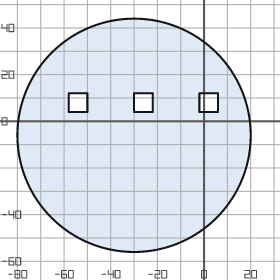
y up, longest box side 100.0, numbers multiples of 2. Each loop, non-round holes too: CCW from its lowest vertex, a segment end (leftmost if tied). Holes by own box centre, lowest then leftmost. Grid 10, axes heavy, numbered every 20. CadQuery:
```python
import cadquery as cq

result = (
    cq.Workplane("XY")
    .moveTo(-30.0, -6.0)
    .circle(50.0)
    .moveTo(-58.0, 4.0)
    .lineTo(-50.0, 4.0)
    .lineTo(-50.0, 12.0)
    .lineTo(-58.0, 12.0)
    .close()
    .moveTo(-30.0, 4.0)
    .lineTo(-22.0, 4.0)
    .lineTo(-22.0, 12.0)
    .lineTo(-30.0, 12.0)
    .close()
    .moveTo(-2.0, 4.0)
    .lineTo(6.0, 4.0)
    .lineTo(6.0, 12.0)
    .lineTo(-2.0, 12.0)
    .close()
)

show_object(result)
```